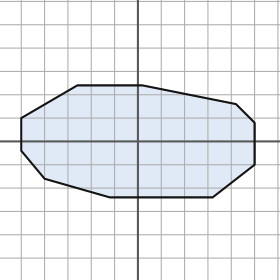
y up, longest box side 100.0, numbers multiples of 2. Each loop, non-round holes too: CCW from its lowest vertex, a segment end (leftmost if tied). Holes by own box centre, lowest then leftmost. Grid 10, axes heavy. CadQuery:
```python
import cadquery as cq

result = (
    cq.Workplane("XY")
    .moveTo(-12.0, -24.0)
    .lineTo(32.0, -24.0)
    .lineTo(50.0, -10.0)
    .lineTo(50.0, 8.0)
    .lineTo(42.0, 16.0)
    .lineTo(2.0, 24.0)
    .lineTo(-26.0, 24.0)
    .lineTo(-50.0, 10.0)
    .lineTo(-50.0, -4.0)
    .lineTo(-40.0, -16.0)
    .close()
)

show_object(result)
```